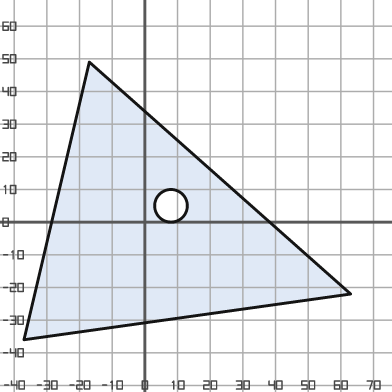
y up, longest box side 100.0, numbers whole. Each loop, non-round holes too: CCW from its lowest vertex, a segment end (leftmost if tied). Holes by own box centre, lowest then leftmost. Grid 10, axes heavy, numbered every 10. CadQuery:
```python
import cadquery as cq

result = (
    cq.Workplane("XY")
    .moveTo(-37.0, -36.0)
    .lineTo(63.0, -22.0)
    .lineTo(-17.0, 49.0)
    .close()
    .moveTo(8.0, 5.0)
    .circle(5.0)
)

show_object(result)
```